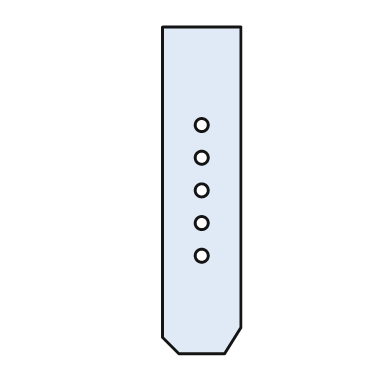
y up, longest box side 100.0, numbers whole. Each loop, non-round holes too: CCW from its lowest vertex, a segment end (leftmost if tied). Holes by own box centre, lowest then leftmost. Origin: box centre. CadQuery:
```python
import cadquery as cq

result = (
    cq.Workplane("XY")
    .moveTo(-7.0, -50.0)
    .lineTo(7.0, -50.0)
    .lineTo(12.0, -42.0)
    .lineTo(12.0, 50.0)
    .lineTo(-12.0, 50.0)
    .lineTo(-12.0, -45.0)
    .close()
    .moveTo(0.0, -20.0)
    .circle(2.0)
    .moveTo(0.0, -10.0)
    .circle(2.0)
    .moveTo(0.0, 0.0)
    .circle(2.0)
    .moveTo(0.0, 10.0)
    .circle(2.0)
    .moveTo(0.0, 20.0)
    .circle(2.0)
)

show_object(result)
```